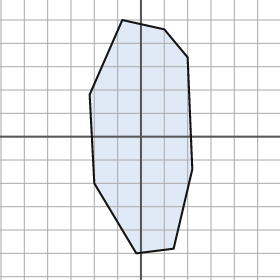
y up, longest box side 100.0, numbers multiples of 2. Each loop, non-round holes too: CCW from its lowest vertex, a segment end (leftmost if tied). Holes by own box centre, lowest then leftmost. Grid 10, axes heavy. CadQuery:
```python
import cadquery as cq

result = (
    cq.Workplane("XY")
    .moveTo(-2.0, -50.0)
    .lineTo(14.0, -48.0)
    .lineTo(22.0, -14.0)
    .lineTo(20.0, 34.0)
    .lineTo(10.0, 46.0)
    .lineTo(-8.0, 50.0)
    .lineTo(-22.0, 18.0)
    .lineTo(-20.0, -20.0)
    .close()
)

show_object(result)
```